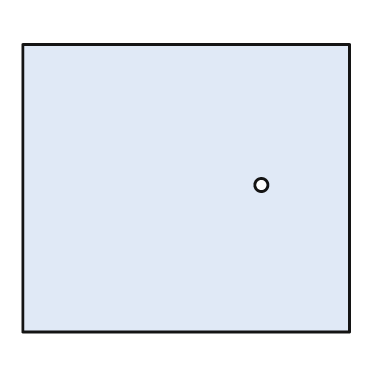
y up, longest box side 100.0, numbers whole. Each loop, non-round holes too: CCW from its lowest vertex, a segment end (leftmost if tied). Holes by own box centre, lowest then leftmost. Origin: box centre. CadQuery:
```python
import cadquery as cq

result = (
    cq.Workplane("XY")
    .moveTo(-50.0, -44.0)
    .lineTo(50.0, -44.0)
    .lineTo(50.0, 44.0)
    .lineTo(-50.0, 44.0)
    .close()
    .moveTo(23.0, 1.0)
    .circle(2.0)
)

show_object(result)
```